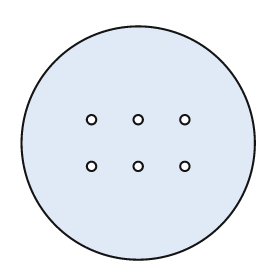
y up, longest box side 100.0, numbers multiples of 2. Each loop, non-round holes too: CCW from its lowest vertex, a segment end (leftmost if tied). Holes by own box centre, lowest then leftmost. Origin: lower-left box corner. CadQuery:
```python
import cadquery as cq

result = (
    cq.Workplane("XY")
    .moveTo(50.0, 50.0)
    .circle(50.0)
    .moveTo(30.0, 40.0)
    .circle(2.0)
    .moveTo(50.0, 40.0)
    .circle(2.0)
    .moveTo(70.0, 40.0)
    .circle(2.0)
    .moveTo(30.0, 60.0)
    .circle(2.0)
    .moveTo(50.0, 60.0)
    .circle(2.0)
    .moveTo(70.0, 60.0)
    .circle(2.0)
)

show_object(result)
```